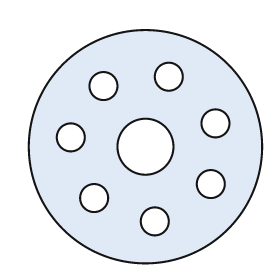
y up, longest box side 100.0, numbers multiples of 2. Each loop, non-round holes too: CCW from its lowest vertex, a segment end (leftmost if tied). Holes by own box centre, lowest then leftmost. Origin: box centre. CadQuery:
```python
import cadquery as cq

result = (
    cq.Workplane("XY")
    .moveTo(0.0, 0.0)
    .circle(50.0)
    .moveTo(4.0, -32.0)
    .circle(6.0)
    .moveTo(-22.0, -22.0)
    .circle(6.0)
    .moveTo(28.0, -16.0)
    .circle(6.0)
    .moveTo(0.0, 0.0)
    .circle(12.0)
    .moveTo(-32.0, 4.0)
    .circle(6.0)
    .moveTo(30.0, 10.0)
    .circle(6.0)
    .moveTo(-18.0, 26.0)
    .circle(6.0)
    .moveTo(10.0, 30.0)
    .circle(6.0)
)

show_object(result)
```